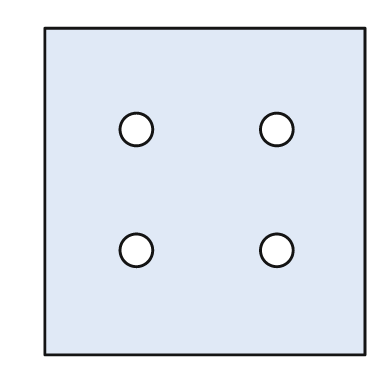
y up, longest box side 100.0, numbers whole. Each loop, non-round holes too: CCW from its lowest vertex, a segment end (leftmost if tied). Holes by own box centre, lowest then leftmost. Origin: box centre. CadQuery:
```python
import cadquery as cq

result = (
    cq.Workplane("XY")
    .moveTo(-49.0, -50.0)
    .lineTo(49.0, -50.0)
    .lineTo(49.0, 50.0)
    .lineTo(-49.0, 50.0)
    .close()
    .moveTo(-21.0, -18.0)
    .circle(5.0)
    .moveTo(22.0, -18.0)
    .circle(5.0)
    .moveTo(-21.0, 19.0)
    .circle(5.0)
    .moveTo(22.0, 19.0)
    .circle(5.0)
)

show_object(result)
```